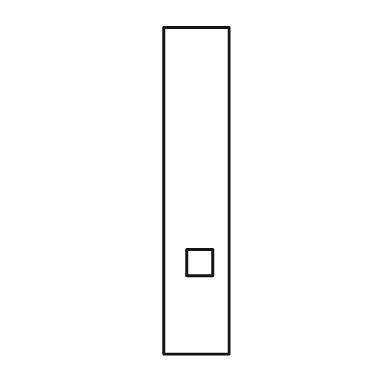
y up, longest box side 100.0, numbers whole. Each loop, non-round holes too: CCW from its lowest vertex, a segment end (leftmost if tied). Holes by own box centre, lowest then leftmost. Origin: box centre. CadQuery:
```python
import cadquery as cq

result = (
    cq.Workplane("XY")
    .moveTo(-10.0, -50.0)
    .lineTo(10.0, -50.0)
    .lineTo(10.0, 50.0)
    .lineTo(-10.0, 50.0)
    .close()
    .moveTo(-3.0, -26.0)
    .lineTo(5.0, -26.0)
    .lineTo(5.0, -18.0)
    .lineTo(-3.0, -18.0)
    .close()
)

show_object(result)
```